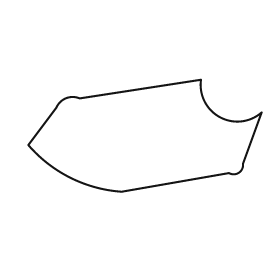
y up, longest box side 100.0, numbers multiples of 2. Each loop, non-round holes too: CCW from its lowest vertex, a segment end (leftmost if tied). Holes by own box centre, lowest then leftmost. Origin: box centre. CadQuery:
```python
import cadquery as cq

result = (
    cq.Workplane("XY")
    .moveTo(-10.0, -24.0)
    .lineTo(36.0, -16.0)
    .threePointArc((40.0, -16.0), (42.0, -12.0))
    .lineTo(50.0, 10.0)
    .threePointArc((32.0, 8.0), (24.0, 24.0))
    .lineTo(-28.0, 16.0)
    .threePointArc((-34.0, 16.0), (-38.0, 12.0))
    .lineTo(-50.0, -4.0)
    .threePointArc((-32.0, -18.0), (-10.0, -24.0))
    .close()
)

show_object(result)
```